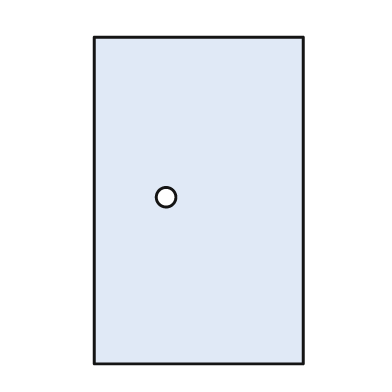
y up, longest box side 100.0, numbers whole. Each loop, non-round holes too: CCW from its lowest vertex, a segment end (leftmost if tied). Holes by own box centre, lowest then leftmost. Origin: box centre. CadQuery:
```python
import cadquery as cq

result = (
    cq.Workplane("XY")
    .moveTo(-32.0, -50.0)
    .lineTo(32.0, -50.0)
    .lineTo(32.0, 50.0)
    .lineTo(-32.0, 50.0)
    .close()
    .moveTo(-10.0, 1.0)
    .circle(3.0)
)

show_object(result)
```